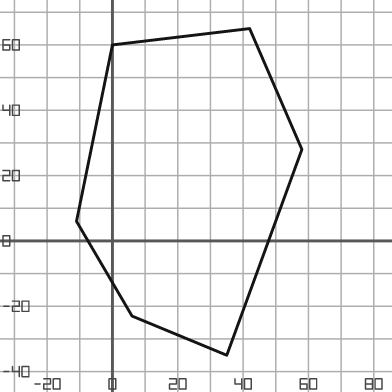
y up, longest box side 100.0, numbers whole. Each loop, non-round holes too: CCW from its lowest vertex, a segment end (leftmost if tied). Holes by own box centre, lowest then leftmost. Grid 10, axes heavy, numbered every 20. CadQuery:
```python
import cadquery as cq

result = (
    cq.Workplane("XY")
    .moveTo(35.0, -35.0)
    .lineTo(58.0, 28.0)
    .lineTo(42.0, 65.0)
    .lineTo(0.0, 60.0)
    .lineTo(-11.0, 6.0)
    .lineTo(6.0, -23.0)
    .close()
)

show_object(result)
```